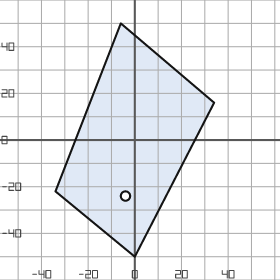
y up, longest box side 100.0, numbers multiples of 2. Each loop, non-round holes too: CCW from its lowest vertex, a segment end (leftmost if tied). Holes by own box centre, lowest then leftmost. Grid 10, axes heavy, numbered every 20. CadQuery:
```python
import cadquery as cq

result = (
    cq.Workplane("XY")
    .moveTo(0.0, -50.0)
    .lineTo(34.0, 16.0)
    .lineTo(-6.0, 50.0)
    .lineTo(-34.0, -22.0)
    .close()
    .moveTo(-4.0, -24.0)
    .circle(2.0)
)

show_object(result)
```